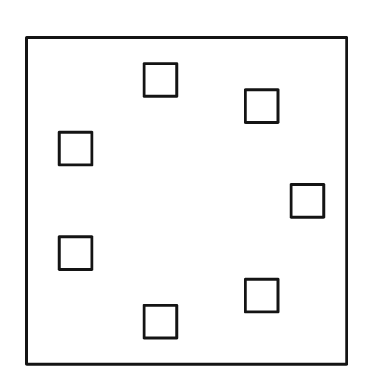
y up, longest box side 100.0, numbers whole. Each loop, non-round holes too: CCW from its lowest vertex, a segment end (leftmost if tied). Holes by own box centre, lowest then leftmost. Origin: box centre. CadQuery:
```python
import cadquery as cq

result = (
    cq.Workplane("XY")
    .moveTo(-49.0, -50.0)
    .lineTo(49.0, -50.0)
    .lineTo(49.0, 50.0)
    .lineTo(-49.0, 50.0)
    .close()
    .moveTo(-13.0, -42.0)
    .lineTo(-3.0, -42.0)
    .lineTo(-3.0, -32.0)
    .lineTo(-13.0, -32.0)
    .close()
    .moveTo(18.0, -34.0)
    .lineTo(28.0, -34.0)
    .lineTo(28.0, -24.0)
    .lineTo(18.0, -24.0)
    .close()
    .moveTo(-39.0, -21.0)
    .lineTo(-29.0, -21.0)
    .lineTo(-29.0, -11.0)
    .lineTo(-39.0, -11.0)
    .close()
    .moveTo(32.0, -5.0)
    .lineTo(42.0, -5.0)
    .lineTo(42.0, 5.0)
    .lineTo(32.0, 5.0)
    .close()
    .moveTo(-39.0, 11.0)
    .lineTo(-29.0, 11.0)
    .lineTo(-29.0, 21.0)
    .lineTo(-39.0, 21.0)
    .close()
    .moveTo(18.0, 24.0)
    .lineTo(28.0, 24.0)
    .lineTo(28.0, 34.0)
    .lineTo(18.0, 34.0)
    .close()
    .moveTo(-13.0, 32.0)
    .lineTo(-3.0, 32.0)
    .lineTo(-3.0, 42.0)
    .lineTo(-13.0, 42.0)
    .close()
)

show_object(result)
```